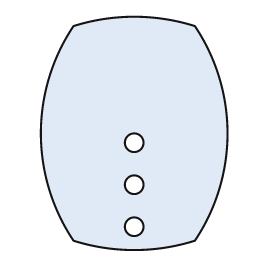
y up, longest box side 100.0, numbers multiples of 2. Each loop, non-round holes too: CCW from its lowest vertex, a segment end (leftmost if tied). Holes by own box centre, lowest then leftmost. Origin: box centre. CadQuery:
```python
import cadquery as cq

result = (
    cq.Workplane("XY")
    .moveTo(-26.0, -46.0)
    .threePointArc((0.0, -50.0), (26.0, -46.0))
    .threePointArc((40.0, 0.0), (26.0, 46.0))
    .threePointArc((0.0, 50.0), (-26.0, 46.0))
    .threePointArc((-40.0, 0.0), (-26.0, -46.0))
    .close()
    .moveTo(0.0, -40.0)
    .circle(4.0)
    .moveTo(0.0, -22.0)
    .circle(4.0)
    .moveTo(0.0, -4.0)
    .circle(4.0)
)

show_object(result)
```